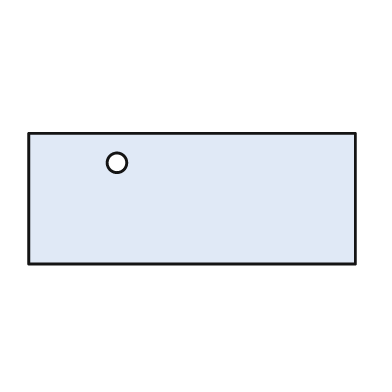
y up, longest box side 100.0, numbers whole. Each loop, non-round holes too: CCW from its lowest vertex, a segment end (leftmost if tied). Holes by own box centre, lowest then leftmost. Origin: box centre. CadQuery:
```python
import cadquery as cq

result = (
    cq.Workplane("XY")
    .moveTo(-50.0, -20.0)
    .lineTo(50.0, -20.0)
    .lineTo(50.0, 20.0)
    .lineTo(-50.0, 20.0)
    .close()
    .moveTo(-23.0, 11.0)
    .circle(3.0)
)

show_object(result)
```